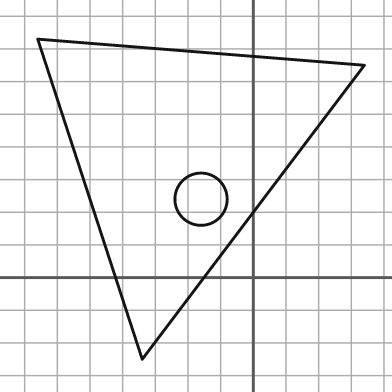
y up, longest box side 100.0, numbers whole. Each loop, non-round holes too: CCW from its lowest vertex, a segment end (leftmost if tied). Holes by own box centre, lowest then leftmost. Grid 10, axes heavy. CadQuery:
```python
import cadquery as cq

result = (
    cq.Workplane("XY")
    .moveTo(-34.0, -25.0)
    .lineTo(34.0, 65.0)
    .lineTo(-66.0, 73.0)
    .close()
    .moveTo(-16.0, 24.0)
    .circle(8.0)
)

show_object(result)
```